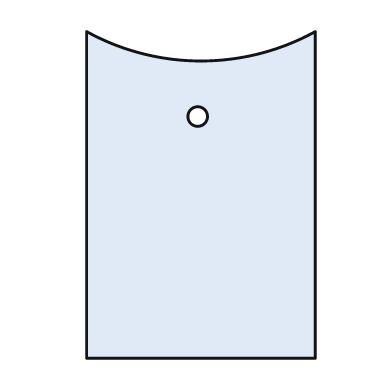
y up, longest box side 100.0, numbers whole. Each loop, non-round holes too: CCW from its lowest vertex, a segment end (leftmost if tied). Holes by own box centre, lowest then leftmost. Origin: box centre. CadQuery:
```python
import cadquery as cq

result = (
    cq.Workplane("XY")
    .moveTo(-35.0, -50.0)
    .lineTo(35.0, -50.0)
    .lineTo(35.0, 50.0)
    .threePointArc((0.0, 41.0), (-35.0, 50.0))
    .close()
    .moveTo(-1.0, 24.0)
    .circle(3.0)
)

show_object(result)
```